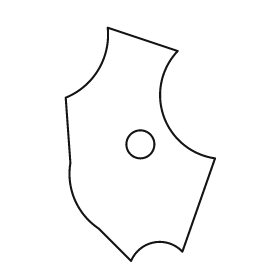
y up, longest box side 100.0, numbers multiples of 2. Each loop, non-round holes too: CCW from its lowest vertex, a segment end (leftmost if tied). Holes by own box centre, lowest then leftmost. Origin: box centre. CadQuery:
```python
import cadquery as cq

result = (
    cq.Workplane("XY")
    .moveTo(-4.0, -50.0)
    .threePointArc((6.0, -42.0), (18.0, -46.0))
    .lineTo(32.0, -6.0)
    .threePointArc((10.0, 12.0), (16.0, 40.0))
    .lineTo(-14.0, 50.0)
    .threePointArc((-18.0, 32.0), (-32.0, 20.0))
    .lineTo(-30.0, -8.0)
    .threePointArc((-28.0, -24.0), (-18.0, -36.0))
    .close()
    .moveTo(0.0, 0.0)
    .circle(6.0)
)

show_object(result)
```